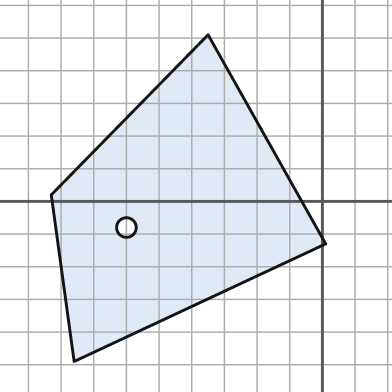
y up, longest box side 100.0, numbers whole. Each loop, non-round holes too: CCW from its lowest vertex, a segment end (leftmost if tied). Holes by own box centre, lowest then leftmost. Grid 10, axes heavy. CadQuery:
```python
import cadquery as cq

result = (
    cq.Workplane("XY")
    .moveTo(-76.0, -49.0)
    .lineTo(1.0, -13.0)
    .lineTo(-35.0, 51.0)
    .lineTo(-83.0, 2.0)
    .close()
    .moveTo(-60.0, -8.0)
    .circle(3.0)
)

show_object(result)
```